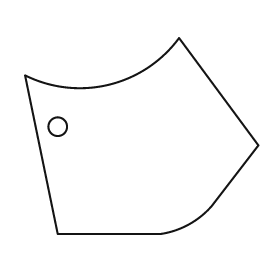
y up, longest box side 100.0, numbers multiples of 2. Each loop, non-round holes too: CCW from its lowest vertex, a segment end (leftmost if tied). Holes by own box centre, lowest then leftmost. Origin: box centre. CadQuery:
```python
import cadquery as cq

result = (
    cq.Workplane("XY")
    .moveTo(-36.0, -42.0)
    .lineTo(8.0, -42.0)
    .threePointArc((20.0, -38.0), (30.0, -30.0))
    .lineTo(50.0, -4.0)
    .lineTo(16.0, 42.0)
    .threePointArc((-14.0, 22.0), (-50.0, 26.0))
    .close()
    .moveTo(-36.0, 4.0)
    .circle(4.0)
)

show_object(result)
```